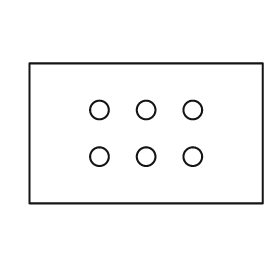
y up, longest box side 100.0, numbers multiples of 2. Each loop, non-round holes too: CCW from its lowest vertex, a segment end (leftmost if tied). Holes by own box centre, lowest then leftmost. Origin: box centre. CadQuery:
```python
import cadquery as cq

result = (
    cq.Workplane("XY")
    .moveTo(-50.0, -30.0)
    .lineTo(50.0, -30.0)
    .lineTo(50.0, 30.0)
    .lineTo(-50.0, 30.0)
    .close()
    .moveTo(-20.0, -10.0)
    .circle(4.0)
    .moveTo(0.0, -10.0)
    .circle(4.0)
    .moveTo(20.0, -10.0)
    .circle(4.0)
    .moveTo(-20.0, 10.0)
    .circle(4.0)
    .moveTo(0.0, 10.0)
    .circle(4.0)
    .moveTo(20.0, 10.0)
    .circle(4.0)
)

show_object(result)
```